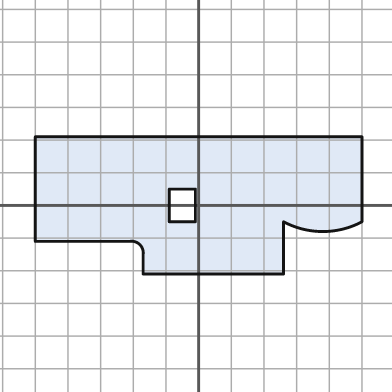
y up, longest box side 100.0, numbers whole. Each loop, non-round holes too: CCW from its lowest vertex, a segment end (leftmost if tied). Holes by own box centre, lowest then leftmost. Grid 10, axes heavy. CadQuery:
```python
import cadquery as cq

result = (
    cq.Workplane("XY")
    .moveTo(-17.0, -21.0)
    .lineTo(26.0, -21.0)
    .lineTo(26.0, -5.0)
    .threePointArc((38.0, -8.0), (50.0, -5.0))
    .lineTo(50.0, 21.0)
    .lineTo(-50.0, 21.0)
    .lineTo(-50.0, -11.0)
    .lineTo(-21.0, -11.0)
    .threePointArc((-18.0, -12.0), (-17.0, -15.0))
    .close()
    .moveTo(-9.0, -5.0)
    .lineTo(-1.0, -5.0)
    .lineTo(-1.0, 5.0)
    .lineTo(-9.0, 5.0)
    .close()
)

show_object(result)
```